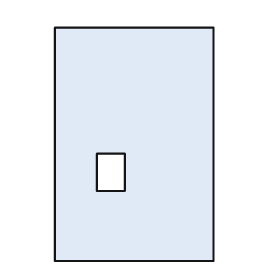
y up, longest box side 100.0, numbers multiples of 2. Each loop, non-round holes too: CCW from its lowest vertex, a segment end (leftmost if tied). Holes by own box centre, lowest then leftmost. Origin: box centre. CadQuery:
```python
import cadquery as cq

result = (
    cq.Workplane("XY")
    .moveTo(-34.0, -50.0)
    .lineTo(34.0, -50.0)
    .lineTo(34.0, 50.0)
    .lineTo(-34.0, 50.0)
    .close()
    .moveTo(-16.0, -20.0)
    .lineTo(-4.0, -20.0)
    .lineTo(-4.0, -4.0)
    .lineTo(-16.0, -4.0)
    .close()
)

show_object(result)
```